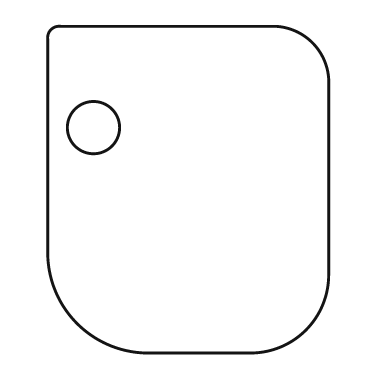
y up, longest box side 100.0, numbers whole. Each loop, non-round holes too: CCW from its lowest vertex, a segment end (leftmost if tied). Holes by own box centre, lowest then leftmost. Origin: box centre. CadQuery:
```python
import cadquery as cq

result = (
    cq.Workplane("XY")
    .moveTo(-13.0, -50.0)
    .lineTo(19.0, -50.0)
    .threePointArc((36.0, -43.0), (43.0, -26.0))
    .lineTo(43.0, 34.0)
    .threePointArc((38.0, 45.0), (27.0, 50.0))
    .lineTo(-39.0, 50.0)
    .threePointArc((-42.0, 49.0), (-43.0, 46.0))
    .lineTo(-43.0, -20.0)
    .threePointArc((-34.0, -41.0), (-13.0, -50.0))
    .close()
    .moveTo(-29.0, 19.0)
    .circle(8.0)
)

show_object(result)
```